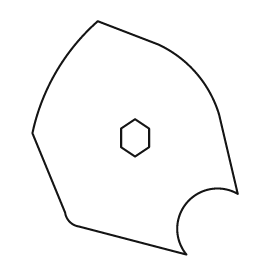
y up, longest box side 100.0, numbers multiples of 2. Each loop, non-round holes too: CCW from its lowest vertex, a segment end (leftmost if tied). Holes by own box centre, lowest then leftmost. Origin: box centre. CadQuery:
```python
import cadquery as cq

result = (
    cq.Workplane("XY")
    .moveTo(22.0, -50.0)
    .threePointArc((22.0, -28.0), (44.0, -24.0))
    .lineTo(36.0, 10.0)
    .threePointArc((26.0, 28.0), (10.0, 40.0))
    .lineTo(-16.0, 50.0)
    .threePointArc((-34.0, 28.0), (-44.0, 2.0))
    .lineTo(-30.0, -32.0)
    .threePointArc((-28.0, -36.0), (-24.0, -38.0))
    .close()
    .moveTo(0.0, -8.0)
    .lineTo(6.0, -4.0)
    .lineTo(6.0, 4.0)
    .lineTo(0.0, 8.0)
    .lineTo(-6.0, 4.0)
    .lineTo(-6.0, -4.0)
    .close()
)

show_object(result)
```